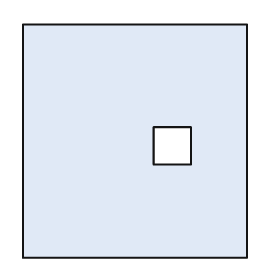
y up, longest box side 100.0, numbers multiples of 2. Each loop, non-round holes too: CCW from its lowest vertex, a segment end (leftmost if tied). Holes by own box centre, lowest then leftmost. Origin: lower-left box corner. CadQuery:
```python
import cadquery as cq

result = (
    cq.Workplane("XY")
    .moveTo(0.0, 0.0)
    .lineTo(96.0, 0.0)
    .lineTo(96.0, 100.0)
    .lineTo(0.0, 100.0)
    .close()
    .moveTo(56.0, 40.0)
    .lineTo(72.0, 40.0)
    .lineTo(72.0, 56.0)
    .lineTo(56.0, 56.0)
    .close()
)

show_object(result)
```